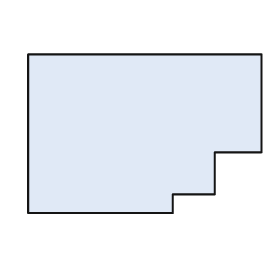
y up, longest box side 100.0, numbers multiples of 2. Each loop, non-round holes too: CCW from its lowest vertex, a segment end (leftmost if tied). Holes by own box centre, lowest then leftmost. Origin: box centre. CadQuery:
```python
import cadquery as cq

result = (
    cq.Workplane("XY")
    .moveTo(-50.0, -34.0)
    .lineTo(12.0, -34.0)
    .lineTo(12.0, -26.0)
    .lineTo(30.0, -26.0)
    .lineTo(30.0, -8.0)
    .lineTo(50.0, -8.0)
    .lineTo(50.0, 34.0)
    .lineTo(-50.0, 34.0)
    .close()
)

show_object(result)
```